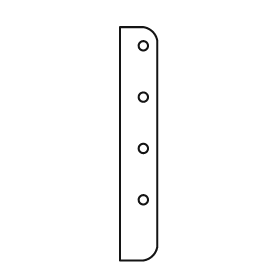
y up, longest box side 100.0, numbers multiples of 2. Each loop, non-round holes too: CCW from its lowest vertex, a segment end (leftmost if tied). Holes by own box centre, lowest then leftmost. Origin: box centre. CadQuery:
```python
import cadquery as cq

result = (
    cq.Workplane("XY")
    .moveTo(-8.0, -50.0)
    .lineTo(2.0, -50.0)
    .threePointArc((6.0, -48.0), (8.0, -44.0))
    .lineTo(8.0, 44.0)
    .threePointArc((6.0, 48.0), (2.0, 50.0))
    .lineTo(-8.0, 50.0)
    .close()
    .moveTo(2.0, -24.0)
    .circle(2.0)
    .moveTo(2.0, -2.0)
    .circle(2.0)
    .moveTo(2.0, 20.0)
    .circle(2.0)
    .moveTo(2.0, 42.0)
    .circle(2.0)
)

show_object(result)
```